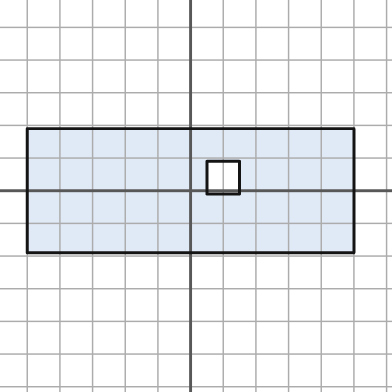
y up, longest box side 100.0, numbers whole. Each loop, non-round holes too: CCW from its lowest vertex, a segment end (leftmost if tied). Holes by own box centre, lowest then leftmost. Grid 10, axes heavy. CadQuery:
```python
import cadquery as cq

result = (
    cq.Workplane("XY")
    .moveTo(-50.0, -19.0)
    .lineTo(50.0, -19.0)
    .lineTo(50.0, 19.0)
    .lineTo(-50.0, 19.0)
    .close()
    .moveTo(5.0, -1.0)
    .lineTo(15.0, -1.0)
    .lineTo(15.0, 9.0)
    .lineTo(5.0, 9.0)
    .close()
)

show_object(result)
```